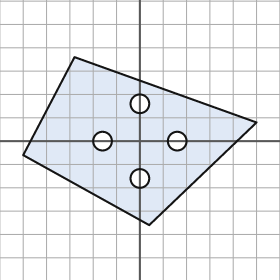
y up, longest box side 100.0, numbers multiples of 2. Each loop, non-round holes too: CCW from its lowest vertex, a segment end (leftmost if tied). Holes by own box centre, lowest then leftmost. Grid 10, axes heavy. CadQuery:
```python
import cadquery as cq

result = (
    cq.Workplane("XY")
    .moveTo(4.0, -36.0)
    .lineTo(50.0, 8.0)
    .lineTo(-28.0, 36.0)
    .lineTo(-50.0, -6.0)
    .close()
    .moveTo(0.0, -16.0)
    .circle(4.0)
    .moveTo(-16.0, 0.0)
    .circle(4.0)
    .moveTo(16.0, 0.0)
    .circle(4.0)
    .moveTo(0.0, 16.0)
    .circle(4.0)
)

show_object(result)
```